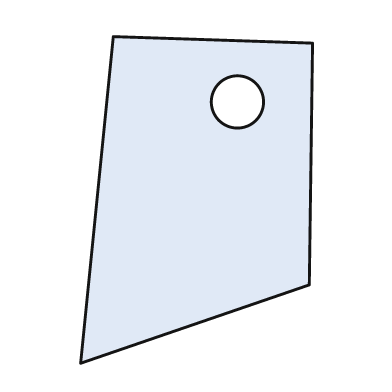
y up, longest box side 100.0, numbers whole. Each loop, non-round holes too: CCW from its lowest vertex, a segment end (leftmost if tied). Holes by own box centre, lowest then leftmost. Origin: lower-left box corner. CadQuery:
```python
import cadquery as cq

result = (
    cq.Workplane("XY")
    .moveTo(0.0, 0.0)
    .lineTo(70.0, 24.0)
    .lineTo(71.0, 98.0)
    .lineTo(10.0, 100.0)
    .close()
    .moveTo(48.0, 80.0)
    .circle(8.0)
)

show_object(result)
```